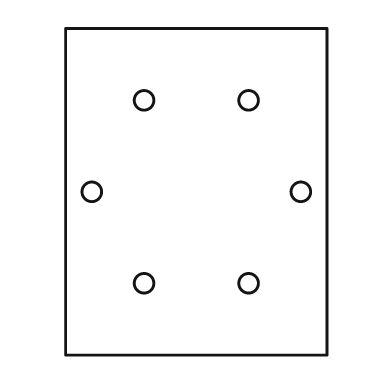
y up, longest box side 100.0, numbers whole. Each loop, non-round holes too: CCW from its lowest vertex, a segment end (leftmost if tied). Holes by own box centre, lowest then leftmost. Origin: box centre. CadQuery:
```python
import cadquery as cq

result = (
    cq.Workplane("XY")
    .moveTo(-40.0, -50.0)
    .lineTo(40.0, -50.0)
    .lineTo(40.0, 50.0)
    .lineTo(-40.0, 50.0)
    .close()
    .moveTo(-16.0, -28.0)
    .circle(3.0)
    .moveTo(16.0, -28.0)
    .circle(3.0)
    .moveTo(-32.0, 0.0)
    .circle(3.0)
    .moveTo(32.0, 0.0)
    .circle(3.0)
    .moveTo(-16.0, 28.0)
    .circle(3.0)
    .moveTo(16.0, 28.0)
    .circle(3.0)
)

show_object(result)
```